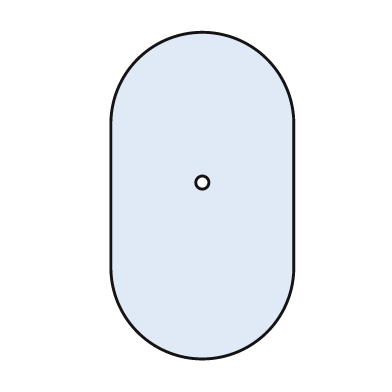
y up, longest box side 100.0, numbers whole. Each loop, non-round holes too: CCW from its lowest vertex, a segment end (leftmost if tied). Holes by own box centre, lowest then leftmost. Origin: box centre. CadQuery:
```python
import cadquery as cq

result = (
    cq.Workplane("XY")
    .moveTo(-28.0, -22.0)
    .threePointArc((0.0, -50.0), (28.0, -22.0))
    .lineTo(28.0, 22.0)
    .threePointArc((0.0, 50.0), (-28.0, 22.0))
    .close()
    .moveTo(0.0, 4.0)
    .circle(2.0)
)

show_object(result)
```